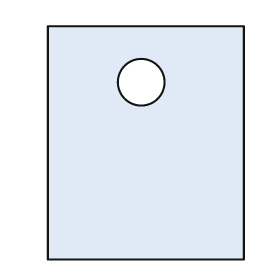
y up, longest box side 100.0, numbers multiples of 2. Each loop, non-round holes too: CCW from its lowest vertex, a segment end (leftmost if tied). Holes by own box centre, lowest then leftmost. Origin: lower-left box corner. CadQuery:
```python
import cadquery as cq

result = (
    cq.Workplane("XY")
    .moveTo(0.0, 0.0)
    .lineTo(84.0, 0.0)
    .lineTo(84.0, 100.0)
    .lineTo(0.0, 100.0)
    .close()
    .moveTo(40.0, 76.0)
    .circle(10.0)
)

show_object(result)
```